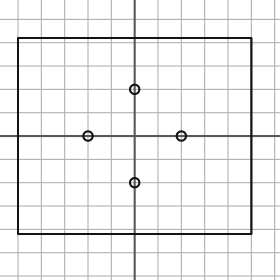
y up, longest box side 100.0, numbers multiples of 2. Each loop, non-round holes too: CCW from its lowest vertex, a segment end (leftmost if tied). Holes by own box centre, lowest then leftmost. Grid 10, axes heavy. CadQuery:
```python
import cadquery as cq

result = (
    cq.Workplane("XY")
    .moveTo(-50.0, -42.0)
    .lineTo(50.0, -42.0)
    .lineTo(50.0, 42.0)
    .lineTo(-50.0, 42.0)
    .close()
    .moveTo(0.0, -20.0)
    .circle(2.0)
    .moveTo(-20.0, 0.0)
    .circle(2.0)
    .moveTo(20.0, 0.0)
    .circle(2.0)
    .moveTo(0.0, 20.0)
    .circle(2.0)
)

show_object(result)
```